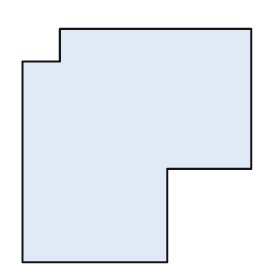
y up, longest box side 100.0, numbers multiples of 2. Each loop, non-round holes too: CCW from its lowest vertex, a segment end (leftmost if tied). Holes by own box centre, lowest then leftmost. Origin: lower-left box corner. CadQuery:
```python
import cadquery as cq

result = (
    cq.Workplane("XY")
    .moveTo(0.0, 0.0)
    .lineTo(62.0, 0.0)
    .lineTo(62.0, 40.0)
    .lineTo(98.0, 40.0)
    .lineTo(98.0, 100.0)
    .lineTo(16.0, 100.0)
    .lineTo(16.0, 86.0)
    .lineTo(0.0, 86.0)
    .close()
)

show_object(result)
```